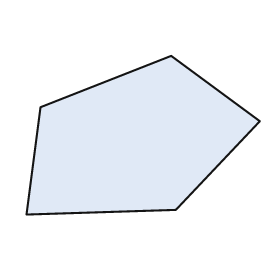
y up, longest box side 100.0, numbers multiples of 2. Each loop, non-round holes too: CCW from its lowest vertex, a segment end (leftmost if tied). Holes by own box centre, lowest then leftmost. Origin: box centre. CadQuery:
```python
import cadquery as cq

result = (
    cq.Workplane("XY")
    .moveTo(-50.0, -34.0)
    .lineTo(14.0, -32.0)
    .lineTo(50.0, 6.0)
    .lineTo(12.0, 34.0)
    .lineTo(-44.0, 12.0)
    .close()
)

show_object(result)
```